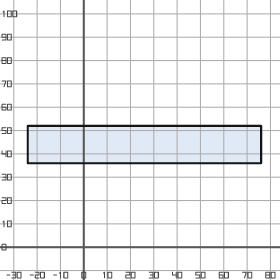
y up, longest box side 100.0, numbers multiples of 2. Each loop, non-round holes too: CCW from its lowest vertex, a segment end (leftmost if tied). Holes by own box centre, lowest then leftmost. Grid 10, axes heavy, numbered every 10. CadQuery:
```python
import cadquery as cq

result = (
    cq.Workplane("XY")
    .moveTo(-24.0, 36.0)
    .lineTo(76.0, 36.0)
    .lineTo(76.0, 52.0)
    .lineTo(-24.0, 52.0)
    .close()
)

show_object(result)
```